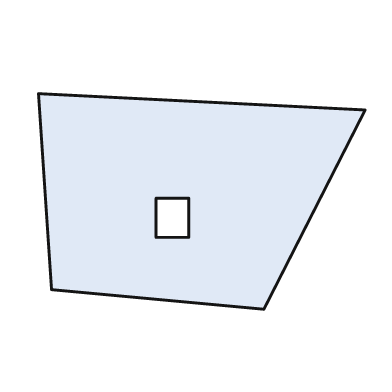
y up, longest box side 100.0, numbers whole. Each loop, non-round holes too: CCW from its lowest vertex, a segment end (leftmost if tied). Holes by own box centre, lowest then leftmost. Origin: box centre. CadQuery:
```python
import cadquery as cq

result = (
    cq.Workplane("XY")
    .moveTo(19.0, -33.0)
    .lineTo(50.0, 28.0)
    .lineTo(-50.0, 33.0)
    .lineTo(-46.0, -27.0)
    .close()
    .moveTo(-14.0, -11.0)
    .lineTo(-4.0, -11.0)
    .lineTo(-4.0, 1.0)
    .lineTo(-14.0, 1.0)
    .close()
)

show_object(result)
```